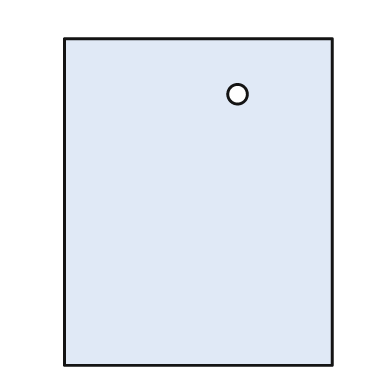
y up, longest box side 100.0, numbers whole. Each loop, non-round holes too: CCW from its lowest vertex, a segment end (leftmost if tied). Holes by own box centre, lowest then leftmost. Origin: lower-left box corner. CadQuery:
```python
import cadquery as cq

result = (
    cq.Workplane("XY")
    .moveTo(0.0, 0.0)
    .lineTo(82.0, 0.0)
    .lineTo(82.0, 100.0)
    .lineTo(0.0, 100.0)
    .close()
    .moveTo(53.0, 83.0)
    .circle(3.0)
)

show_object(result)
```